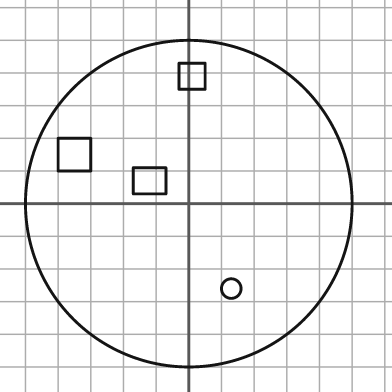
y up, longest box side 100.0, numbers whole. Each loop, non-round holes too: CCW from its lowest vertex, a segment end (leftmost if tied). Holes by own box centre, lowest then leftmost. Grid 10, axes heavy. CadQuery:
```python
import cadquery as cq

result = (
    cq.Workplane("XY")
    .moveTo(0.0, 0.0)
    .circle(50.0)
    .moveTo(13.0, -26.0)
    .circle(3.0)
    .moveTo(-17.0, 3.0)
    .lineTo(-7.0, 3.0)
    .lineTo(-7.0, 11.0)
    .lineTo(-17.0, 11.0)
    .close()
    .moveTo(-40.0, 10.0)
    .lineTo(-30.0, 10.0)
    .lineTo(-30.0, 20.0)
    .lineTo(-40.0, 20.0)
    .close()
    .moveTo(-3.0, 35.0)
    .lineTo(5.0, 35.0)
    .lineTo(5.0, 43.0)
    .lineTo(-3.0, 43.0)
    .close()
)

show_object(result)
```